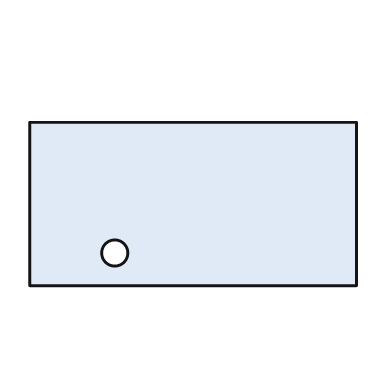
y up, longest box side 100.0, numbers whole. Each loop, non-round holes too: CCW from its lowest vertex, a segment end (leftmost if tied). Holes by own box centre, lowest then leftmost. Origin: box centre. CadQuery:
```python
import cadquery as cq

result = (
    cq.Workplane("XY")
    .moveTo(-50.0, -25.0)
    .lineTo(50.0, -25.0)
    .lineTo(50.0, 25.0)
    .lineTo(-50.0, 25.0)
    .close()
    .moveTo(-24.0, -15.0)
    .circle(4.0)
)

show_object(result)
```